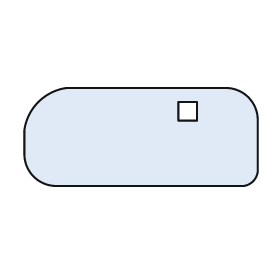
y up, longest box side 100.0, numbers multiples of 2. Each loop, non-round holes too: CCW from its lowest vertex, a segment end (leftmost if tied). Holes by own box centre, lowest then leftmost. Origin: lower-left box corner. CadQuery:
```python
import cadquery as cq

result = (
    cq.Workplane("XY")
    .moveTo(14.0, 0.0)
    .lineTo(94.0, 0.0)
    .threePointArc((98.0, 2.0), (100.0, 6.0))
    .lineTo(100.0, 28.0)
    .threePointArc((96.0, 38.0), (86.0, 42.0))
    .lineTo(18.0, 42.0)
    .threePointArc((6.0, 36.0), (0.0, 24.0))
    .lineTo(0.0, 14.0)
    .threePointArc((4.0, 4.0), (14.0, 0.0))
    .close()
    .moveTo(66.0, 28.0)
    .lineTo(74.0, 28.0)
    .lineTo(74.0, 36.0)
    .lineTo(66.0, 36.0)
    .close()
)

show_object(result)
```